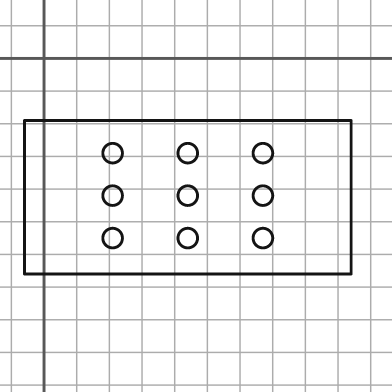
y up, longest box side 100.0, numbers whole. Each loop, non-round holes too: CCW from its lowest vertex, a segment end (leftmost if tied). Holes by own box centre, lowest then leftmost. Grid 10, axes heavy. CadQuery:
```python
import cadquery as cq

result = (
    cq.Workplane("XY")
    .moveTo(-6.0, -66.0)
    .lineTo(94.0, -66.0)
    .lineTo(94.0, -19.0)
    .lineTo(-6.0, -19.0)
    .close()
    .moveTo(21.0, -55.0)
    .circle(3.0)
    .moveTo(44.0, -55.0)
    .circle(3.0)
    .moveTo(67.0, -55.0)
    .circle(3.0)
    .moveTo(21.0, -42.0)
    .circle(3.0)
    .moveTo(44.0, -42.0)
    .circle(3.0)
    .moveTo(67.0, -42.0)
    .circle(3.0)
    .moveTo(21.0, -29.0)
    .circle(3.0)
    .moveTo(44.0, -29.0)
    .circle(3.0)
    .moveTo(67.0, -29.0)
    .circle(3.0)
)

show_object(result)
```